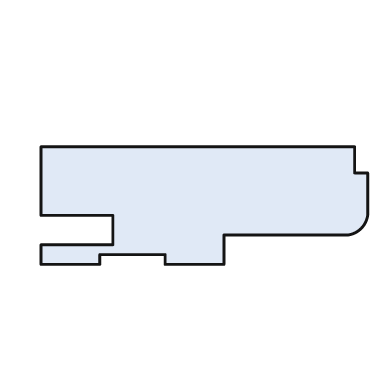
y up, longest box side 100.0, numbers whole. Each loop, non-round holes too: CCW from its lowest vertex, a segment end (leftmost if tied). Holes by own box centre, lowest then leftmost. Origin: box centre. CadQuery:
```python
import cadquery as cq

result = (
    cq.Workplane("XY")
    .moveTo(-50.0, -18.0)
    .lineTo(-32.0, -18.0)
    .lineTo(-32.0, -15.0)
    .lineTo(-12.0, -15.0)
    .lineTo(-12.0, -18.0)
    .lineTo(6.0, -18.0)
    .lineTo(6.0, -9.0)
    .lineTo(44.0, -9.0)
    .threePointArc((48.0, -7.0), (50.0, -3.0))
    .lineTo(50.0, 10.0)
    .lineTo(46.0, 10.0)
    .lineTo(46.0, 18.0)
    .lineTo(-50.0, 18.0)
    .lineTo(-50.0, -3.0)
    .lineTo(-28.0, -3.0)
    .lineTo(-28.0, -12.0)
    .lineTo(-50.0, -12.0)
    .close()
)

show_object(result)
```